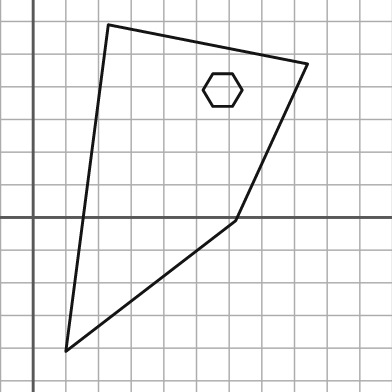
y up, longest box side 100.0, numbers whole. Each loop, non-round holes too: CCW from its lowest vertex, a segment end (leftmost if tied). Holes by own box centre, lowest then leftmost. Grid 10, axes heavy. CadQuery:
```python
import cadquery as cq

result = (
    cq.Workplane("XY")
    .moveTo(10.0, -41.0)
    .lineTo(62.0, -1.0)
    .lineTo(84.0, 47.0)
    .lineTo(23.0, 59.0)
    .close()
    .moveTo(55.0, 34.0)
    .lineTo(61.0, 34.0)
    .lineTo(64.0, 39.0)
    .lineTo(61.0, 44.0)
    .lineTo(55.0, 44.0)
    .lineTo(52.0, 39.0)
    .close()
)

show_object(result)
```